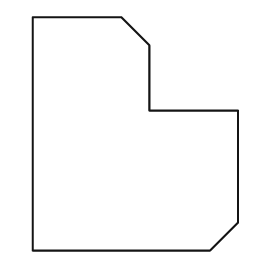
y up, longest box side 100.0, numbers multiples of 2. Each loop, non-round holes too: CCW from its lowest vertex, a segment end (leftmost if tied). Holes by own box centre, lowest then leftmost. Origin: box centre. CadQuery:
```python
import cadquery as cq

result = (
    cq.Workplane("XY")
    .moveTo(-44.0, -50.0)
    .lineTo(32.0, -50.0)
    .lineTo(44.0, -38.0)
    .lineTo(44.0, 10.0)
    .lineTo(6.0, 10.0)
    .lineTo(6.0, 38.0)
    .lineTo(-6.0, 50.0)
    .lineTo(-44.0, 50.0)
    .close()
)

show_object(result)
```